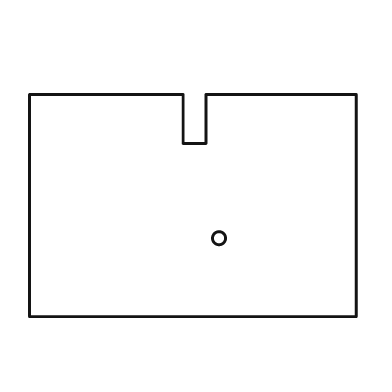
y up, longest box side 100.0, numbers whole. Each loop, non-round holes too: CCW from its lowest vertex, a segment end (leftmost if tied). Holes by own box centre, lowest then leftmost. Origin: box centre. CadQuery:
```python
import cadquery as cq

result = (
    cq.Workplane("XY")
    .moveTo(-50.0, -34.0)
    .lineTo(50.0, -34.0)
    .lineTo(50.0, 34.0)
    .lineTo(4.0, 34.0)
    .lineTo(4.0, 19.0)
    .lineTo(-3.0, 19.0)
    .lineTo(-3.0, 34.0)
    .lineTo(-50.0, 34.0)
    .close()
    .moveTo(8.0, -10.0)
    .circle(2.0)
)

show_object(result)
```